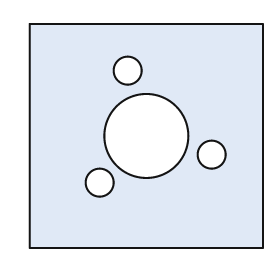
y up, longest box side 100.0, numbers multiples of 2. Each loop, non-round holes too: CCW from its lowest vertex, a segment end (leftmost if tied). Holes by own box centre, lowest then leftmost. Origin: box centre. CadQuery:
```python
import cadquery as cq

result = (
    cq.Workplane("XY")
    .moveTo(-50.0, -48.0)
    .lineTo(50.0, -48.0)
    .lineTo(50.0, 48.0)
    .lineTo(-50.0, 48.0)
    .close()
    .moveTo(-20.0, -20.0)
    .circle(6.0)
    .moveTo(28.0, -8.0)
    .circle(6.0)
    .moveTo(0.0, 0.0)
    .circle(18.0)
    .moveTo(-8.0, 28.0)
    .circle(6.0)
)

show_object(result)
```